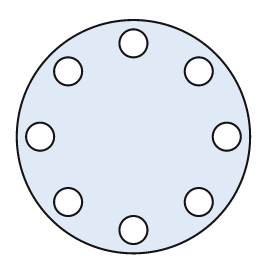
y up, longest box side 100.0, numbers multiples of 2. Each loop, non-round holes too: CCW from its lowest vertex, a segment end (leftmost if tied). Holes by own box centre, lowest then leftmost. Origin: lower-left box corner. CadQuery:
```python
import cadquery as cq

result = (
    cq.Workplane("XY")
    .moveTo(50.0, 50.0)
    .circle(50.0)
    .moveTo(50.0, 10.0)
    .circle(6.0)
    .moveTo(22.0, 22.0)
    .circle(6.0)
    .moveTo(78.0, 22.0)
    .circle(6.0)
    .moveTo(10.0, 50.0)
    .circle(6.0)
    .moveTo(90.0, 50.0)
    .circle(6.0)
    .moveTo(22.0, 78.0)
    .circle(6.0)
    .moveTo(78.0, 78.0)
    .circle(6.0)
    .moveTo(50.0, 90.0)
    .circle(6.0)
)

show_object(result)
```